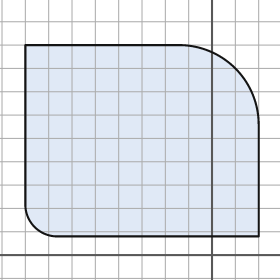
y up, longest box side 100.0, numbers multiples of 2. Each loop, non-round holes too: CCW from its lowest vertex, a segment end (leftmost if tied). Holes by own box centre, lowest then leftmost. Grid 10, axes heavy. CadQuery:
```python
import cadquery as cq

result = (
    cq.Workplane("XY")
    .moveTo(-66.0, 8.0)
    .lineTo(20.0, 8.0)
    .lineTo(20.0, 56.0)
    .threePointArc((10.0, 80.0), (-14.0, 90.0))
    .lineTo(-80.0, 90.0)
    .lineTo(-80.0, 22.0)
    .threePointArc((-76.0, 12.0), (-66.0, 8.0))
    .close()
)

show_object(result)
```